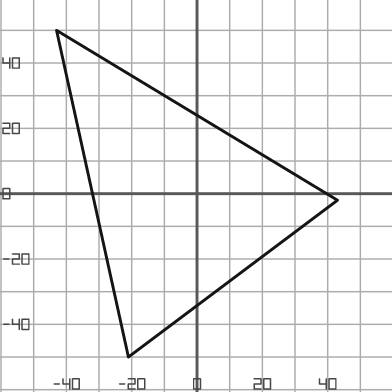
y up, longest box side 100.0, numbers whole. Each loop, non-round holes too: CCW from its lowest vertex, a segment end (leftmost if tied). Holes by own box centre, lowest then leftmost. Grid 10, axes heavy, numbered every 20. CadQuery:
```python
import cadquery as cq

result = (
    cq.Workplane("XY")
    .moveTo(-21.0, -50.0)
    .lineTo(43.0, -2.0)
    .lineTo(-43.0, 50.0)
    .close()
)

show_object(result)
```